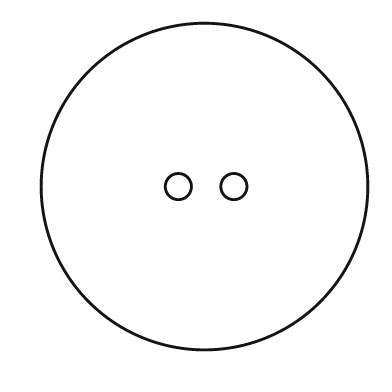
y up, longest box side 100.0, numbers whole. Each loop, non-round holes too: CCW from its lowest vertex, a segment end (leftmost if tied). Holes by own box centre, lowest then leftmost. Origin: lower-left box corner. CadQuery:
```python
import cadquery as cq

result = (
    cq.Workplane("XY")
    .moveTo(50.0, 50.0)
    .circle(50.0)
    .moveTo(42.0, 50.0)
    .circle(4.0)
    .moveTo(59.0, 50.0)
    .circle(4.0)
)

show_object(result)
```